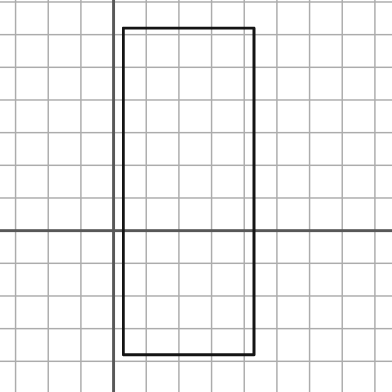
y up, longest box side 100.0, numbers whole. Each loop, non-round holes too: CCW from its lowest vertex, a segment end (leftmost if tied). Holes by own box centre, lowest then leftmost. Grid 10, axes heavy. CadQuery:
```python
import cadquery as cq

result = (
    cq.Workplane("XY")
    .moveTo(3.0, -38.0)
    .lineTo(43.0, -38.0)
    .lineTo(43.0, 62.0)
    .lineTo(3.0, 62.0)
    .close()
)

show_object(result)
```